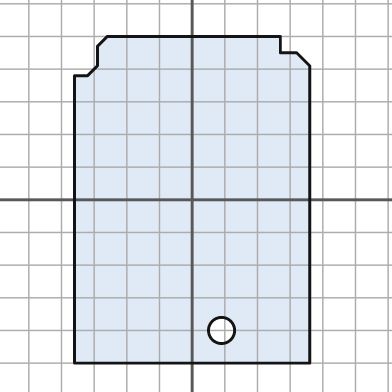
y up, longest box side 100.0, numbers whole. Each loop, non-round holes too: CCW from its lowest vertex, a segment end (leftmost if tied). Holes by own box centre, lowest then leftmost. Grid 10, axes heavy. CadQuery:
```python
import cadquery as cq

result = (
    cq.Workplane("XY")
    .moveTo(-36.0, -50.0)
    .lineTo(36.0, -50.0)
    .lineTo(36.0, 41.0)
    .lineTo(32.0, 45.0)
    .lineTo(27.0, 45.0)
    .lineTo(27.0, 50.0)
    .lineTo(-26.0, 50.0)
    .lineTo(-29.0, 47.0)
    .lineTo(-29.0, 41.0)
    .lineTo(-32.0, 38.0)
    .lineTo(-36.0, 38.0)
    .close()
    .moveTo(9.0, -40.0)
    .circle(4.0)
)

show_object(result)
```